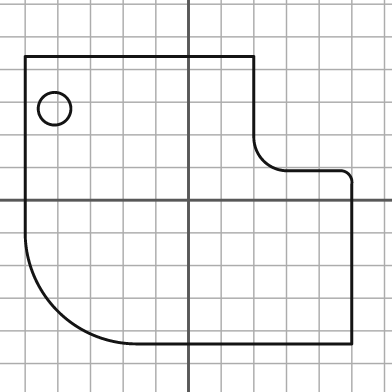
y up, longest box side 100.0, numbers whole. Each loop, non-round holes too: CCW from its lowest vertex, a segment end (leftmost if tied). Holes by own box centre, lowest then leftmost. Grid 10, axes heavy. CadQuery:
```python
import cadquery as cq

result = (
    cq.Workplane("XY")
    .moveTo(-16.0, -44.0)
    .lineTo(50.0, -44.0)
    .lineTo(50.0, 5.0)
    .threePointArc((49.0, 8.0), (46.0, 9.0))
    .lineTo(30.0, 9.0)
    .threePointArc((23.0, 12.0), (20.0, 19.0))
    .lineTo(20.0, 44.0)
    .lineTo(-50.0, 44.0)
    .lineTo(-50.0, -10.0)
    .threePointArc((-40.0, -34.0), (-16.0, -44.0))
    .close()
    .moveTo(-41.0, 28.0)
    .circle(5.0)
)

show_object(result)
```